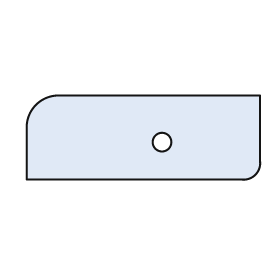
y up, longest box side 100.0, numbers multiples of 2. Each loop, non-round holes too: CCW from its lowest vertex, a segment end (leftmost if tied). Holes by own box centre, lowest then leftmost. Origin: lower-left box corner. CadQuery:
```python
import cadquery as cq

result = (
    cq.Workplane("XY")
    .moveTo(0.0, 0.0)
    .lineTo(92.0, 0.0)
    .threePointArc((98.0, 2.0), (100.0, 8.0))
    .lineTo(100.0, 36.0)
    .lineTo(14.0, 36.0)
    .threePointArc((4.0, 32.0), (0.0, 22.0))
    .close()
    .moveTo(58.0, 16.0)
    .circle(4.0)
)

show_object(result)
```